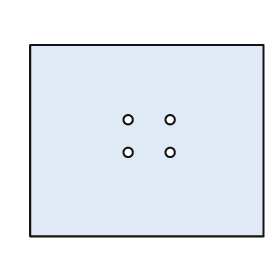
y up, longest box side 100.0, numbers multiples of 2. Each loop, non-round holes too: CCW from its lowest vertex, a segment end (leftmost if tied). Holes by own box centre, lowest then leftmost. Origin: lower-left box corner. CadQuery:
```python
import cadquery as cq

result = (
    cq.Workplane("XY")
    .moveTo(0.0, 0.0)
    .lineTo(100.0, 0.0)
    .lineTo(100.0, 82.0)
    .lineTo(0.0, 82.0)
    .close()
    .moveTo(42.0, 36.0)
    .circle(2.0)
    .moveTo(60.0, 36.0)
    .circle(2.0)
    .moveTo(42.0, 50.0)
    .circle(2.0)
    .moveTo(60.0, 50.0)
    .circle(2.0)
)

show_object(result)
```